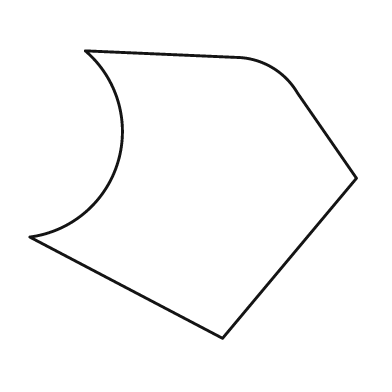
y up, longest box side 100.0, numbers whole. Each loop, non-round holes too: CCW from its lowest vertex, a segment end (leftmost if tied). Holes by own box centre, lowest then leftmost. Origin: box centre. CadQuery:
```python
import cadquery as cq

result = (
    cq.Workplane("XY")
    .moveTo(9.0, -44.0)
    .lineTo(50.0, 5.0)
    .lineTo(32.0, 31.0)
    .threePointArc((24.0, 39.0), (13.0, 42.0))
    .lineTo(-33.0, 44.0)
    .threePointArc((-23.0, 10.0), (-50.0, -13.0))
    .close()
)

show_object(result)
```